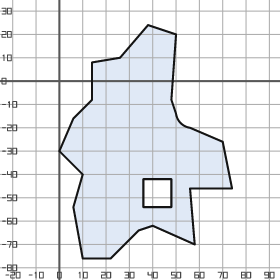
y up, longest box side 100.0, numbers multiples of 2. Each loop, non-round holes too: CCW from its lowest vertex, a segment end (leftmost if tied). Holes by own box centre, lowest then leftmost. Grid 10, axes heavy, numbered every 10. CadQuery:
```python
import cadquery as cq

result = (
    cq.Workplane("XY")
    .moveTo(10.0, -76.0)
    .lineTo(22.0, -76.0)
    .lineTo(34.0, -64.0)
    .lineTo(40.0, -62.0)
    .lineTo(58.0, -70.0)
    .lineTo(56.0, -46.0)
    .lineTo(74.0, -46.0)
    .lineTo(70.0, -26.0)
    .lineTo(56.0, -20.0)
    .threePointArc((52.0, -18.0), (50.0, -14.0))
    .lineTo(48.0, -8.0)
    .lineTo(50.0, 20.0)
    .lineTo(38.0, 24.0)
    .lineTo(26.0, 10.0)
    .lineTo(14.0, 8.0)
    .lineTo(14.0, -8.0)
    .lineTo(6.0, -16.0)
    .lineTo(0.0, -30.0)
    .lineTo(10.0, -40.0)
    .lineTo(6.0, -54.0)
    .close()
    .moveTo(36.0, -54.0)
    .lineTo(48.0, -54.0)
    .lineTo(48.0, -42.0)
    .lineTo(36.0, -42.0)
    .close()
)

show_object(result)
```